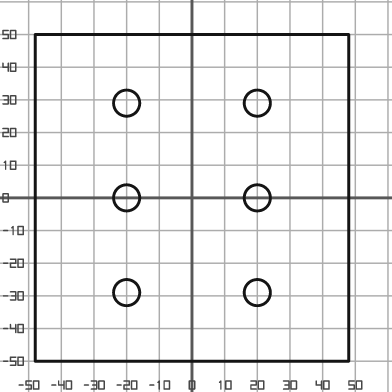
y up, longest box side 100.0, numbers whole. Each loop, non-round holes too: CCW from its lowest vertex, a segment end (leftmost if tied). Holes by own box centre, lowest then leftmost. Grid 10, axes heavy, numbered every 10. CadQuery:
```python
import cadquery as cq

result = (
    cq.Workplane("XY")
    .moveTo(-48.0, -50.0)
    .lineTo(48.0, -50.0)
    .lineTo(48.0, 50.0)
    .lineTo(-48.0, 50.0)
    .close()
    .moveTo(-20.0, -29.0)
    .circle(4.0)
    .moveTo(20.0, -29.0)
    .circle(4.0)
    .moveTo(-20.0, 0.0)
    .circle(4.0)
    .moveTo(20.0, 0.0)
    .circle(4.0)
    .moveTo(-20.0, 29.0)
    .circle(4.0)
    .moveTo(20.0, 29.0)
    .circle(4.0)
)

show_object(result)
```